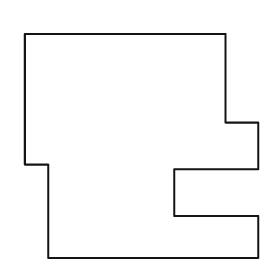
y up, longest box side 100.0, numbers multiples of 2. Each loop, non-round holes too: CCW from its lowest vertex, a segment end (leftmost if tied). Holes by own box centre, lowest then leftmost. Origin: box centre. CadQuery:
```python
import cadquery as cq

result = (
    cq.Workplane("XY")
    .moveTo(-40.0, -48.0)
    .lineTo(50.0, -48.0)
    .lineTo(50.0, -30.0)
    .lineTo(14.0, -30.0)
    .lineTo(14.0, -10.0)
    .lineTo(50.0, -10.0)
    .lineTo(50.0, 10.0)
    .lineTo(36.0, 10.0)
    .lineTo(36.0, 48.0)
    .lineTo(-50.0, 48.0)
    .lineTo(-50.0, -8.0)
    .lineTo(-40.0, -8.0)
    .close()
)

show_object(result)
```